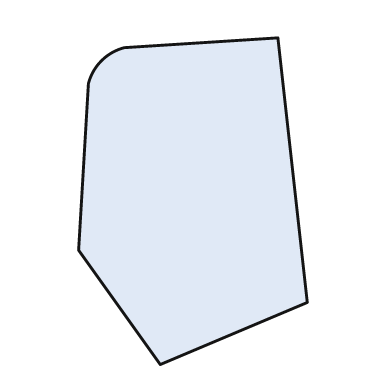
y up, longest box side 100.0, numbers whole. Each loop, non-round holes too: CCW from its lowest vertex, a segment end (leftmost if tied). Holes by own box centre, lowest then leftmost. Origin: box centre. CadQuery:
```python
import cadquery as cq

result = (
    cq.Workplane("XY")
    .moveTo(-10.0, -50.0)
    .lineTo(35.0, -31.0)
    .lineTo(26.0, 50.0)
    .lineTo(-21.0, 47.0)
    .threePointArc((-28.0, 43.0), (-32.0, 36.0))
    .lineTo(-35.0, -15.0)
    .close()
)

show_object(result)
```